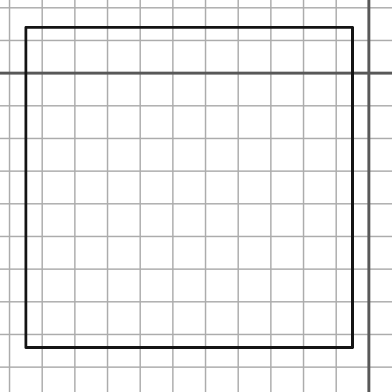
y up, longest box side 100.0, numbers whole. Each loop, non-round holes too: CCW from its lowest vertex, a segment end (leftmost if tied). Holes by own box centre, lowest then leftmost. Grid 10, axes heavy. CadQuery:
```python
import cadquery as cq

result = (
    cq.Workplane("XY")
    .moveTo(-105.0, -84.0)
    .lineTo(-5.0, -84.0)
    .lineTo(-5.0, 14.0)
    .lineTo(-105.0, 14.0)
    .close()
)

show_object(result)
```